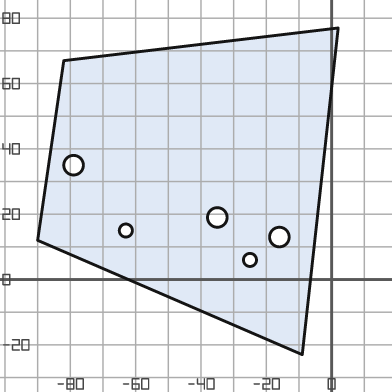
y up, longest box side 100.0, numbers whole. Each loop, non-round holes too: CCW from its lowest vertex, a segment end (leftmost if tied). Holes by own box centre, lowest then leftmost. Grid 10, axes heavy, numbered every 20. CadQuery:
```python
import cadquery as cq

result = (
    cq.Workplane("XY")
    .moveTo(-9.0, -23.0)
    .lineTo(2.0, 77.0)
    .lineTo(-82.0, 67.0)
    .lineTo(-90.0, 12.0)
    .close()
    .moveTo(-25.0, 6.0)
    .circle(2.0)
    .moveTo(-16.0, 13.0)
    .circle(3.0)
    .moveTo(-63.0, 15.0)
    .circle(2.0)
    .moveTo(-35.0, 19.0)
    .circle(3.0)
    .moveTo(-79.0, 35.0)
    .circle(3.0)
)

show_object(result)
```